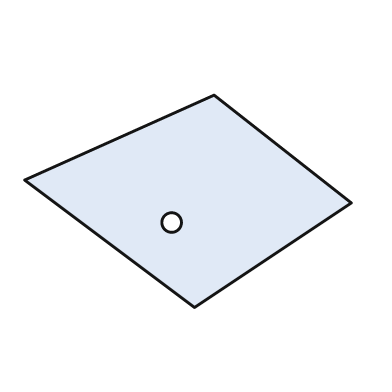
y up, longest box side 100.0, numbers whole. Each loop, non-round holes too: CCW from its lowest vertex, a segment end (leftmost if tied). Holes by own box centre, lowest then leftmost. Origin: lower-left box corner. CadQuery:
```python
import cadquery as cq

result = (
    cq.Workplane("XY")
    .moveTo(52.0, 0.0)
    .lineTo(100.0, 32.0)
    .lineTo(58.0, 65.0)
    .lineTo(0.0, 39.0)
    .close()
    .moveTo(45.0, 26.0)
    .circle(3.0)
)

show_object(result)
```